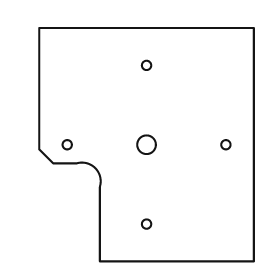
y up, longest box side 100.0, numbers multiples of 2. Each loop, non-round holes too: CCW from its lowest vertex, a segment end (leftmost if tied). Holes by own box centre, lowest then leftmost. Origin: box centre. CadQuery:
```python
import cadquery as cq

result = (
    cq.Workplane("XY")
    .moveTo(-20.0, -50.0)
    .lineTo(46.0, -50.0)
    .lineTo(46.0, 50.0)
    .lineTo(-46.0, 50.0)
    .lineTo(-46.0, -2.0)
    .lineTo(-40.0, -8.0)
    .lineTo(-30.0, -8.0)
    .threePointArc((-22.0, -10.0), (-20.0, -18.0))
    .close()
    .moveTo(0.0, -34.0)
    .circle(2.0)
    .moveTo(-34.0, 0.0)
    .circle(2.0)
    .moveTo(0.0, 0.0)
    .circle(4.0)
    .moveTo(34.0, 0.0)
    .circle(2.0)
    .moveTo(0.0, 34.0)
    .circle(2.0)
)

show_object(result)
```